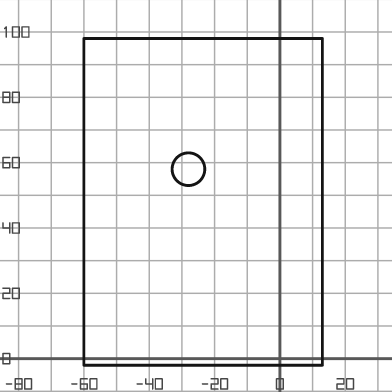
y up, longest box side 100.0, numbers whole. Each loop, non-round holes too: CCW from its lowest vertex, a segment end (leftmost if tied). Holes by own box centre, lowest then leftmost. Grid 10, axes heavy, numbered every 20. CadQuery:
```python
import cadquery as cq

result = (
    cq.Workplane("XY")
    .moveTo(-60.0, -2.0)
    .lineTo(13.0, -2.0)
    .lineTo(13.0, 98.0)
    .lineTo(-60.0, 98.0)
    .close()
    .moveTo(-28.0, 58.0)
    .circle(5.0)
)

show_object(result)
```